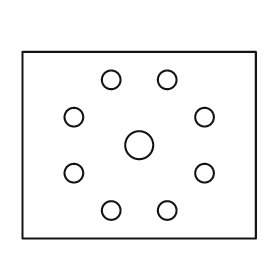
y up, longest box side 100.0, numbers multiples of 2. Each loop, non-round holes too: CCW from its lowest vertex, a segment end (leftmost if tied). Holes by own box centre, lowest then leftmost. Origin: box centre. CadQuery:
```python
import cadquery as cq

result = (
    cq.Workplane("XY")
    .moveTo(-50.0, -40.0)
    .lineTo(50.0, -40.0)
    .lineTo(50.0, 40.0)
    .lineTo(-50.0, 40.0)
    .close()
    .moveTo(-12.0, -28.0)
    .circle(4.0)
    .moveTo(12.0, -28.0)
    .circle(4.0)
    .moveTo(-28.0, -12.0)
    .circle(4.0)
    .moveTo(28.0, -12.0)
    .circle(4.0)
    .moveTo(0.0, 0.0)
    .circle(6.0)
    .moveTo(-28.0, 12.0)
    .circle(4.0)
    .moveTo(28.0, 12.0)
    .circle(4.0)
    .moveTo(-12.0, 28.0)
    .circle(4.0)
    .moveTo(12.0, 28.0)
    .circle(4.0)
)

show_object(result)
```